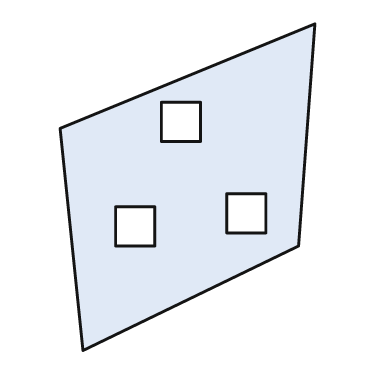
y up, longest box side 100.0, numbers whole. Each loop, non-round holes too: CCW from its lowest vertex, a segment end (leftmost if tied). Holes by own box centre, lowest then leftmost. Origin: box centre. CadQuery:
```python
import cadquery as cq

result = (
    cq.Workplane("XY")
    .moveTo(-32.0, -50.0)
    .lineTo(34.0, -18.0)
    .lineTo(39.0, 50.0)
    .lineTo(-39.0, 18.0)
    .close()
    .moveTo(-22.0, -18.0)
    .lineTo(-10.0, -18.0)
    .lineTo(-10.0, -6.0)
    .lineTo(-22.0, -6.0)
    .close()
    .moveTo(12.0, -14.0)
    .lineTo(24.0, -14.0)
    .lineTo(24.0, -2.0)
    .lineTo(12.0, -2.0)
    .close()
    .moveTo(-8.0, 14.0)
    .lineTo(4.0, 14.0)
    .lineTo(4.0, 26.0)
    .lineTo(-8.0, 26.0)
    .close()
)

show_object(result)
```